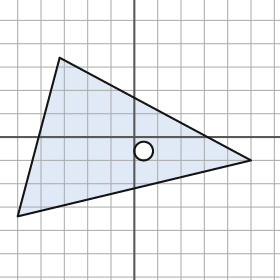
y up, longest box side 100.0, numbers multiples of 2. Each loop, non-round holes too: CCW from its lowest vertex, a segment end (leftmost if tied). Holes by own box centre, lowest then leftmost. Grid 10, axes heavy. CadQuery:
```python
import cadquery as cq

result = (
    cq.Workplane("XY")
    .moveTo(-50.0, -34.0)
    .lineTo(50.0, -10.0)
    .lineTo(-32.0, 34.0)
    .close()
    .moveTo(4.0, -6.0)
    .circle(4.0)
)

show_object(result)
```